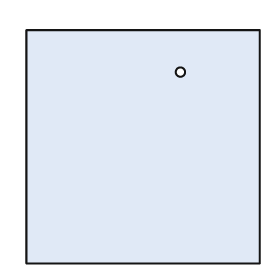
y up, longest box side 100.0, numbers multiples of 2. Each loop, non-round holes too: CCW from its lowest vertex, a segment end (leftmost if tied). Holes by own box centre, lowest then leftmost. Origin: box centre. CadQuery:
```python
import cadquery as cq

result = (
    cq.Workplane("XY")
    .moveTo(-50.0, -50.0)
    .lineTo(50.0, -50.0)
    .lineTo(50.0, 50.0)
    .lineTo(-50.0, 50.0)
    .close()
    .moveTo(16.0, 32.0)
    .circle(2.0)
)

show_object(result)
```